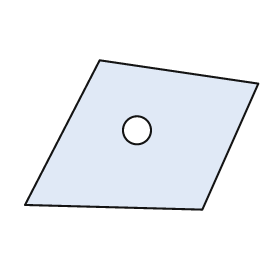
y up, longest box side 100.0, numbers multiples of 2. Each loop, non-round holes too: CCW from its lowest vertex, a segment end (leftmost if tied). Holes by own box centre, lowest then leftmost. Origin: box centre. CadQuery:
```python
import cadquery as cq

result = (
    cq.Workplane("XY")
    .moveTo(26.0, -32.0)
    .lineTo(50.0, 22.0)
    .lineTo(-18.0, 32.0)
    .lineTo(-50.0, -30.0)
    .close()
    .moveTo(-2.0, 2.0)
    .circle(6.0)
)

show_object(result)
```